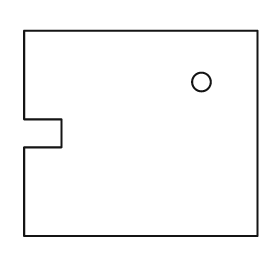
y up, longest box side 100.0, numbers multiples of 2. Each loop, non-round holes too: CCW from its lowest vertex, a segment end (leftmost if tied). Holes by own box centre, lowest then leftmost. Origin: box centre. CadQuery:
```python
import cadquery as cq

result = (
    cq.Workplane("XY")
    .moveTo(-50.0, -44.0)
    .lineTo(50.0, -44.0)
    .lineTo(50.0, 44.0)
    .lineTo(-50.0, 44.0)
    .lineTo(-50.0, 6.0)
    .lineTo(-34.0, 6.0)
    .lineTo(-34.0, -6.0)
    .lineTo(-50.0, -6.0)
    .close()
    .moveTo(26.0, 22.0)
    .circle(4.0)
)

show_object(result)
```